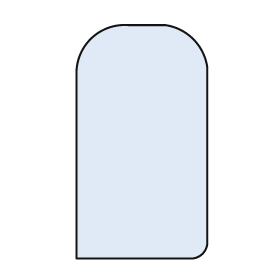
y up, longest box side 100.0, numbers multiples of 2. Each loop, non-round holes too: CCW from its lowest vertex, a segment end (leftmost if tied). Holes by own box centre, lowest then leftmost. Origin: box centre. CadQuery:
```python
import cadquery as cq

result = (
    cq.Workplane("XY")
    .moveTo(-28.0, -50.0)
    .lineTo(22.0, -50.0)
    .threePointArc((26.0, -48.0), (28.0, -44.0))
    .lineTo(28.0, 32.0)
    .threePointArc((22.0, 44.0), (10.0, 50.0))
    .lineTo(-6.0, 50.0)
    .threePointArc((-22.0, 44.0), (-28.0, 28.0))
    .close()
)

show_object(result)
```